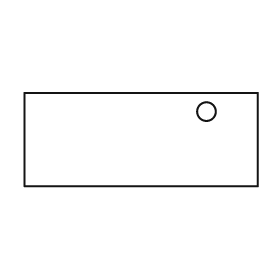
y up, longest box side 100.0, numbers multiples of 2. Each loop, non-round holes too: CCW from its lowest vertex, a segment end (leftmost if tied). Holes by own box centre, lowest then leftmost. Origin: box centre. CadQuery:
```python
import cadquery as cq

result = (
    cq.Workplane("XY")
    .moveTo(-50.0, -20.0)
    .lineTo(50.0, -20.0)
    .lineTo(50.0, 20.0)
    .lineTo(-50.0, 20.0)
    .close()
    .moveTo(28.0, 12.0)
    .circle(4.0)
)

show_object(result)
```